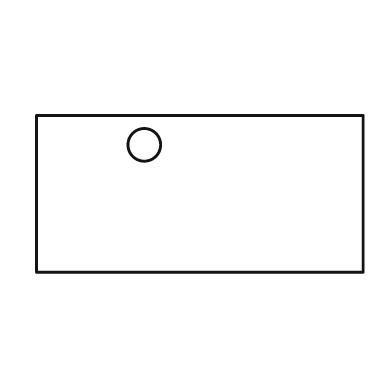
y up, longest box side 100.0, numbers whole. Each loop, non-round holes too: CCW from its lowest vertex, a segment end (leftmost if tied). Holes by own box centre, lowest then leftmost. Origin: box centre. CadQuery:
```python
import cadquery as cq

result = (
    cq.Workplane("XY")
    .moveTo(-50.0, -24.0)
    .lineTo(50.0, -24.0)
    .lineTo(50.0, 24.0)
    .lineTo(-50.0, 24.0)
    .close()
    .moveTo(-17.0, 15.0)
    .circle(5.0)
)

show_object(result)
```